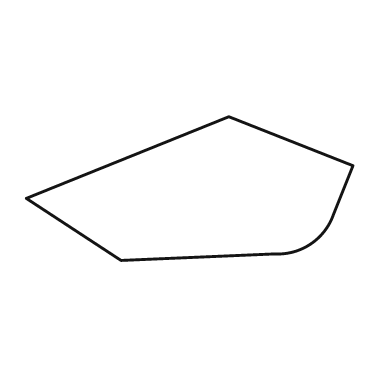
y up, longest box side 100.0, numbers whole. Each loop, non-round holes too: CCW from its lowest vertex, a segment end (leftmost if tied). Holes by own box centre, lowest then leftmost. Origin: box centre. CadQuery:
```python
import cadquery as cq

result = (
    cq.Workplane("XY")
    .moveTo(-21.0, -22.0)
    .lineTo(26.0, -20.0)
    .threePointArc((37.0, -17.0), (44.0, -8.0))
    .lineTo(50.0, 7.0)
    .lineTo(12.0, 22.0)
    .lineTo(-50.0, -3.0)
    .close()
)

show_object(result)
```